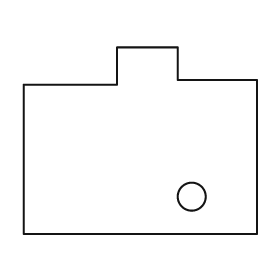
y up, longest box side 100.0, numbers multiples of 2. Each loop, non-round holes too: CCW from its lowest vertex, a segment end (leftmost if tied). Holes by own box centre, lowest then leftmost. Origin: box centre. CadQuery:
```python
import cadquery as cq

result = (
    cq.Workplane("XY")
    .moveTo(-50.0, -40.0)
    .lineTo(50.0, -40.0)
    .lineTo(50.0, 26.0)
    .lineTo(16.0, 26.0)
    .lineTo(16.0, 40.0)
    .lineTo(-10.0, 40.0)
    .lineTo(-10.0, 24.0)
    .lineTo(-50.0, 24.0)
    .close()
    .moveTo(22.0, -24.0)
    .circle(6.0)
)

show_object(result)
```